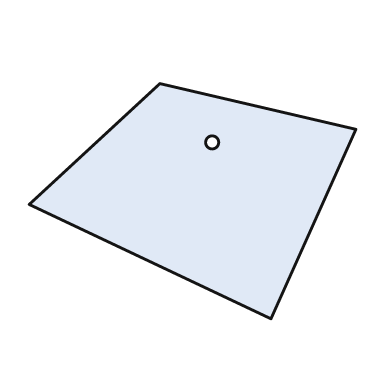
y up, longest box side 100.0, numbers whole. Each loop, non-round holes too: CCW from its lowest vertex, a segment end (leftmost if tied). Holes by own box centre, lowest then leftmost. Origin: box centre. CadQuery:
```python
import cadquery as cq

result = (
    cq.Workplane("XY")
    .moveTo(24.0, -36.0)
    .lineTo(50.0, 22.0)
    .lineTo(-10.0, 36.0)
    .lineTo(-50.0, -1.0)
    .close()
    .moveTo(6.0, 18.0)
    .circle(2.0)
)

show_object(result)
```